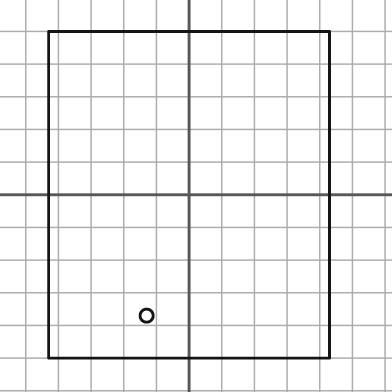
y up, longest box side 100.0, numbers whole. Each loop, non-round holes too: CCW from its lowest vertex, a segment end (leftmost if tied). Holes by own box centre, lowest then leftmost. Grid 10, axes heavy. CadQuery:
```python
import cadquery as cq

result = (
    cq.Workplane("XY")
    .moveTo(-43.0, -50.0)
    .lineTo(43.0, -50.0)
    .lineTo(43.0, 50.0)
    .lineTo(-43.0, 50.0)
    .close()
    .moveTo(-13.0, -37.0)
    .circle(2.0)
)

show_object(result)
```